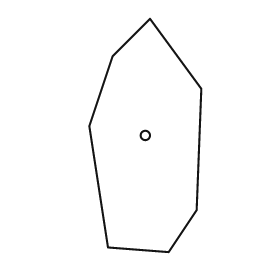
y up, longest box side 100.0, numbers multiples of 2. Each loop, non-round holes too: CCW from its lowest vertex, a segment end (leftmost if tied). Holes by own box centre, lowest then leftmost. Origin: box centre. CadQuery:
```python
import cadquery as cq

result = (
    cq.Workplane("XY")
    .moveTo(10.0, -50.0)
    .lineTo(22.0, -32.0)
    .lineTo(24.0, 20.0)
    .lineTo(2.0, 50.0)
    .lineTo(-14.0, 34.0)
    .lineTo(-24.0, 4.0)
    .lineTo(-16.0, -48.0)
    .close()
    .moveTo(0.0, 0.0)
    .circle(2.0)
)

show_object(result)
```